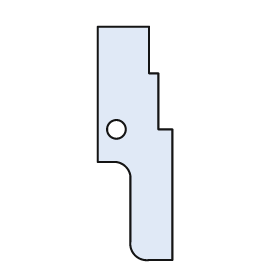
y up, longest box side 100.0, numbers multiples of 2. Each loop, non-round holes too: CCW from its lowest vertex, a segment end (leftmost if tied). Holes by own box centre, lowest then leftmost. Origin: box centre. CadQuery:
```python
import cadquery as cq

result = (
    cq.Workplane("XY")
    .moveTo(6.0, -50.0)
    .lineTo(16.0, -50.0)
    .lineTo(16.0, 6.0)
    .lineTo(10.0, 6.0)
    .lineTo(10.0, 30.0)
    .lineTo(6.0, 30.0)
    .lineTo(6.0, 50.0)
    .lineTo(-16.0, 50.0)
    .lineTo(-16.0, -8.0)
    .lineTo(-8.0, -8.0)
    .threePointArc((-4.0, -10.0), (-2.0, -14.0))
    .lineTo(-2.0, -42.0)
    .threePointArc((0.0, -48.0), (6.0, -50.0))
    .close()
    .moveTo(-8.0, 6.0)
    .circle(4.0)
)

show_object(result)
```